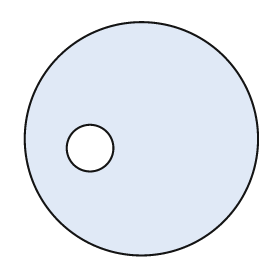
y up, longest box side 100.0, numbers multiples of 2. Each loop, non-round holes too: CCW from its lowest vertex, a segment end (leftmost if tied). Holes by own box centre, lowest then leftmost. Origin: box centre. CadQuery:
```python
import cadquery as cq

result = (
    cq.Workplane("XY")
    .moveTo(0.0, 0.0)
    .circle(50.0)
    .moveTo(-22.0, -4.0)
    .circle(10.0)
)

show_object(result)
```